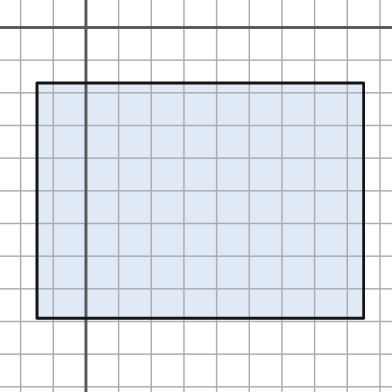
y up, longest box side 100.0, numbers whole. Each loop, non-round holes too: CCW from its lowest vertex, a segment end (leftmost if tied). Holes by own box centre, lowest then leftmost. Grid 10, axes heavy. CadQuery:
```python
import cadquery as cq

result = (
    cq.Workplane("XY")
    .moveTo(-15.0, -89.0)
    .lineTo(85.0, -89.0)
    .lineTo(85.0, -17.0)
    .lineTo(-15.0, -17.0)
    .close()
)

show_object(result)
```